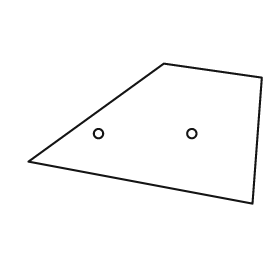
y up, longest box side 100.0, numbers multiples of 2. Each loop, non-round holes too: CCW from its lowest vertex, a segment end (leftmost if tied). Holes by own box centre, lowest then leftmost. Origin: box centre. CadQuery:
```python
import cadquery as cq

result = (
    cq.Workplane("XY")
    .moveTo(46.0, -30.0)
    .lineTo(50.0, 24.0)
    .lineTo(8.0, 30.0)
    .lineTo(-50.0, -12.0)
    .close()
    .moveTo(-20.0, 0.0)
    .circle(2.0)
    .moveTo(20.0, 0.0)
    .circle(2.0)
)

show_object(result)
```